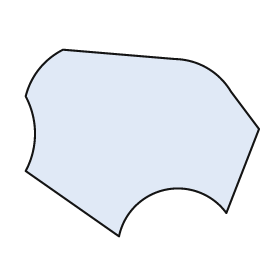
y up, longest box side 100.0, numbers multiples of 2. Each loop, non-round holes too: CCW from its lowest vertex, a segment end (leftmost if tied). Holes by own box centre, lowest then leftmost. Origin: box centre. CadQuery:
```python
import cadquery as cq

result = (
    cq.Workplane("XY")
    .moveTo(-10.0, -40.0)
    .threePointArc((10.0, -20.0), (36.0, -30.0))
    .lineTo(50.0, 6.0)
    .lineTo(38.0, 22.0)
    .threePointArc((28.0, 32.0), (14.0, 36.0))
    .lineTo(-34.0, 40.0)
    .threePointArc((-44.0, 32.0), (-50.0, 20.0))
    .threePointArc((-46.0, 4.0), (-50.0, -12.0))
    .close()
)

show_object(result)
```